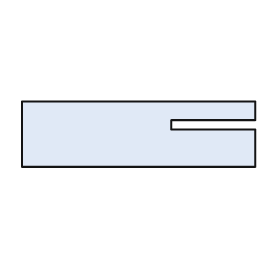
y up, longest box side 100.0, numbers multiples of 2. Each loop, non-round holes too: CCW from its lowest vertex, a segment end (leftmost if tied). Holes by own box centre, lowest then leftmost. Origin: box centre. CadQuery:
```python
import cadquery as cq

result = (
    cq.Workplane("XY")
    .moveTo(-50.0, -14.0)
    .lineTo(50.0, -14.0)
    .lineTo(50.0, 2.0)
    .lineTo(14.0, 2.0)
    .lineTo(14.0, 6.0)
    .lineTo(50.0, 6.0)
    .lineTo(50.0, 14.0)
    .lineTo(-50.0, 14.0)
    .close()
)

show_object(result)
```